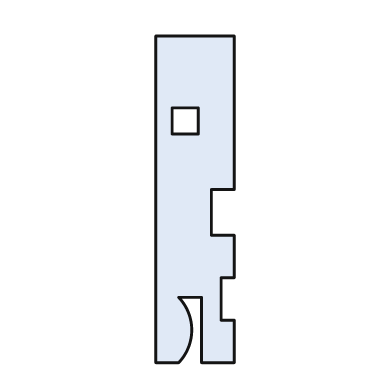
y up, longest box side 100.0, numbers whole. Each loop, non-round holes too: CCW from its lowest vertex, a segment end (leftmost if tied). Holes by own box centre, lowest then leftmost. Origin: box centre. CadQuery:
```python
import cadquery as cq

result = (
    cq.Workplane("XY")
    .moveTo(-12.0, -50.0)
    .lineTo(-5.0, -50.0)
    .threePointArc((-1.0, -40.0), (-5.0, -30.0))
    .lineTo(2.0, -30.0)
    .lineTo(2.0, -50.0)
    .lineTo(12.0, -50.0)
    .lineTo(12.0, -37.0)
    .lineTo(8.0, -37.0)
    .lineTo(8.0, -24.0)
    .lineTo(12.0, -24.0)
    .lineTo(12.0, -11.0)
    .lineTo(5.0, -11.0)
    .lineTo(5.0, 3.0)
    .lineTo(12.0, 3.0)
    .lineTo(12.0, 50.0)
    .lineTo(-12.0, 50.0)
    .close()
    .moveTo(-7.0, 20.0)
    .lineTo(1.0, 20.0)
    .lineTo(1.0, 28.0)
    .lineTo(-7.0, 28.0)
    .close()
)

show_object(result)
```